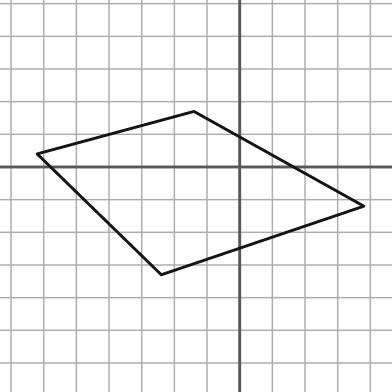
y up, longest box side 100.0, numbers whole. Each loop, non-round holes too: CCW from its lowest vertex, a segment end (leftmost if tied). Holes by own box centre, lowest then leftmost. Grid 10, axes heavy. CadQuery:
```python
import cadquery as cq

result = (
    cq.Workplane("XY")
    .moveTo(-24.0, -33.0)
    .lineTo(38.0, -12.0)
    .lineTo(-14.0, 17.0)
    .lineTo(-62.0, 4.0)
    .close()
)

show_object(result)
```